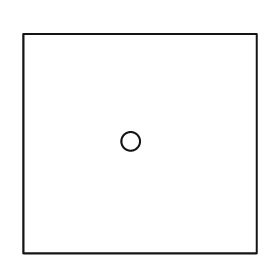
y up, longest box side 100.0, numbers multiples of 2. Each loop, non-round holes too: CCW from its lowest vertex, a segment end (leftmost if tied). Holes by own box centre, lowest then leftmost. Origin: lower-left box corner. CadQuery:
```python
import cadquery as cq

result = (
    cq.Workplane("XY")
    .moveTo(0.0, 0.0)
    .lineTo(100.0, 0.0)
    .lineTo(100.0, 94.0)
    .lineTo(0.0, 94.0)
    .close()
    .moveTo(46.0, 48.0)
    .circle(4.0)
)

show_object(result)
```